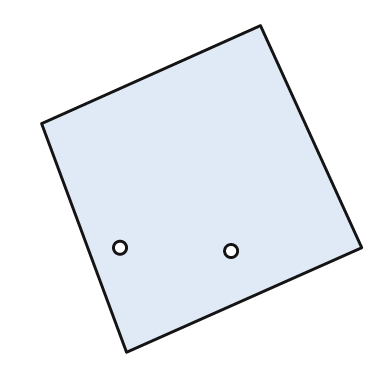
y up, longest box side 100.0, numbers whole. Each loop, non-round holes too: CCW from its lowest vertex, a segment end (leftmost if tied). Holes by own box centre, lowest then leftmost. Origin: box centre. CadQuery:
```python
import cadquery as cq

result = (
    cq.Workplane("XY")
    .moveTo(-23.0, -50.0)
    .lineTo(49.0, -18.0)
    .lineTo(18.0, 50.0)
    .lineTo(-49.0, 20.0)
    .close()
    .moveTo(9.0, -19.0)
    .circle(2.0)
    .moveTo(-25.0, -18.0)
    .circle(2.0)
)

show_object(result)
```